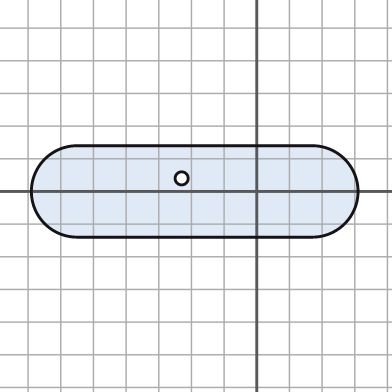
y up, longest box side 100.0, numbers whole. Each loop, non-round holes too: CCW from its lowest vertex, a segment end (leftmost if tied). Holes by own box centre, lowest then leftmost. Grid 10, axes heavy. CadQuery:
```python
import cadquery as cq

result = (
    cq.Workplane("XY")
    .moveTo(-55.0, -14.0)
    .lineTo(17.0, -14.0)
    .threePointArc((31.0, 0.0), (17.0, 14.0))
    .lineTo(-55.0, 14.0)
    .threePointArc((-69.0, 0.0), (-55.0, -14.0))
    .close()
    .moveTo(-23.0, 4.0)
    .circle(2.0)
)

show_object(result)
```